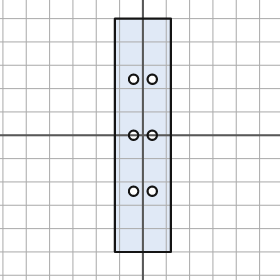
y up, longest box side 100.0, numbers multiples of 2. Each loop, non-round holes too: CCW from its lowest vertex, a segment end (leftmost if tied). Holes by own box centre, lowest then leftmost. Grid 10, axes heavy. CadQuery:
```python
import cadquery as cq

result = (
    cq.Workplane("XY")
    .moveTo(-12.0, -50.0)
    .lineTo(12.0, -50.0)
    .lineTo(12.0, 50.0)
    .lineTo(-12.0, 50.0)
    .close()
    .moveTo(-4.0, -24.0)
    .circle(2.0)
    .moveTo(4.0, -24.0)
    .circle(2.0)
    .moveTo(-4.0, 0.0)
    .circle(2.0)
    .moveTo(4.0, 0.0)
    .circle(2.0)
    .moveTo(-4.0, 24.0)
    .circle(2.0)
    .moveTo(4.0, 24.0)
    .circle(2.0)
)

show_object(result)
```